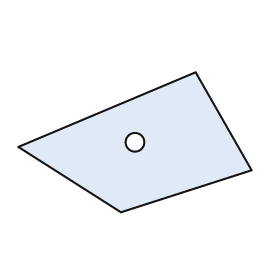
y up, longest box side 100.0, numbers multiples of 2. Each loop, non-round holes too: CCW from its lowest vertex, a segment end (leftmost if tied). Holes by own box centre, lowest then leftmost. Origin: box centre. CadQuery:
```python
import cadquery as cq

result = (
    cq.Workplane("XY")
    .moveTo(-6.0, -30.0)
    .lineTo(50.0, -12.0)
    .lineTo(26.0, 30.0)
    .lineTo(-50.0, -2.0)
    .close()
    .moveTo(0.0, 0.0)
    .circle(4.0)
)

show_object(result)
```